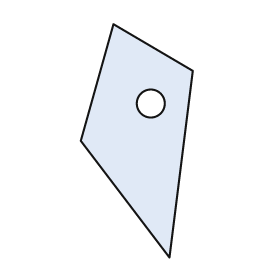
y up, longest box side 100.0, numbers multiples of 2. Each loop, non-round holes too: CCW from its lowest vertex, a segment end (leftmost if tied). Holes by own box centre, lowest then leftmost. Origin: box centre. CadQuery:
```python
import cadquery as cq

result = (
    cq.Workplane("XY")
    .moveTo(14.0, -50.0)
    .lineTo(24.0, 30.0)
    .lineTo(-10.0, 50.0)
    .lineTo(-24.0, 0.0)
    .close()
    .moveTo(6.0, 16.0)
    .circle(6.0)
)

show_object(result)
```